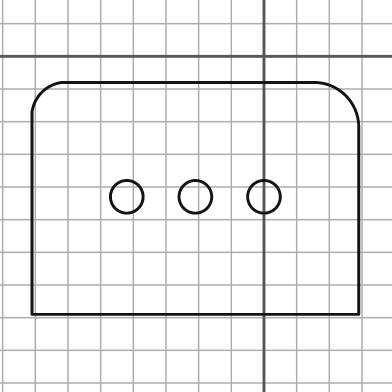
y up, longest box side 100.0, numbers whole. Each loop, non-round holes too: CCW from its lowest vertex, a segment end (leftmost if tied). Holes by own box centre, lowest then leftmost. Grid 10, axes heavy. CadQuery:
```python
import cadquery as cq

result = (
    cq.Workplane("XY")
    .moveTo(-71.0, -79.0)
    .lineTo(29.0, -79.0)
    .lineTo(29.0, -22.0)
    .threePointArc((25.0, -12.0), (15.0, -8.0))
    .lineTo(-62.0, -8.0)
    .threePointArc((-68.0, -11.0), (-71.0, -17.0))
    .close()
    .moveTo(-42.0, -43.0)
    .circle(5.0)
    .moveTo(-21.0, -43.0)
    .circle(5.0)
    .moveTo(0.0, -43.0)
    .circle(5.0)
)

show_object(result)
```